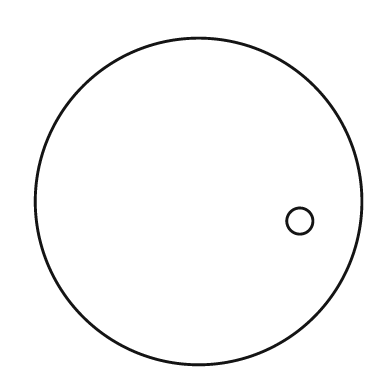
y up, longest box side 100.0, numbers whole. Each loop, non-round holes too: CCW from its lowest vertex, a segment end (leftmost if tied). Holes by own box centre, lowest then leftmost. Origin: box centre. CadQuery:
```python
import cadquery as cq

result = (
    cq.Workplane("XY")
    .moveTo(0.0, 0.0)
    .circle(50.0)
    .moveTo(31.0, -6.0)
    .circle(4.0)
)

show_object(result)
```